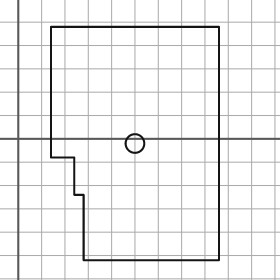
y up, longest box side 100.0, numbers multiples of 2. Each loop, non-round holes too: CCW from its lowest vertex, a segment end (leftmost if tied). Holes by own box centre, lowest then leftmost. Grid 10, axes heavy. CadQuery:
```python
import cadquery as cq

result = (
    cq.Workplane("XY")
    .moveTo(28.0, -52.0)
    .lineTo(86.0, -52.0)
    .lineTo(86.0, 48.0)
    .lineTo(14.0, 48.0)
    .lineTo(14.0, -8.0)
    .lineTo(24.0, -8.0)
    .lineTo(24.0, -24.0)
    .lineTo(28.0, -24.0)
    .close()
    .moveTo(50.0, -2.0)
    .circle(4.0)
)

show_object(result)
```